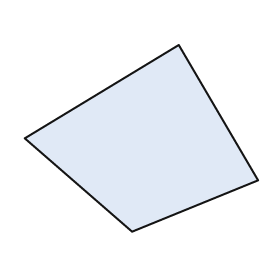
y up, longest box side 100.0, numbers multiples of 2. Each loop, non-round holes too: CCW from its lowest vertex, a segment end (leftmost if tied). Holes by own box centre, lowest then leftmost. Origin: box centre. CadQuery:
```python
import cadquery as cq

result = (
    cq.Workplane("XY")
    .moveTo(-4.0, -40.0)
    .lineTo(50.0, -18.0)
    .lineTo(16.0, 40.0)
    .lineTo(-50.0, 0.0)
    .close()
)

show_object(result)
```